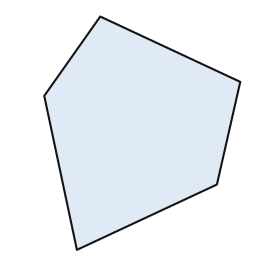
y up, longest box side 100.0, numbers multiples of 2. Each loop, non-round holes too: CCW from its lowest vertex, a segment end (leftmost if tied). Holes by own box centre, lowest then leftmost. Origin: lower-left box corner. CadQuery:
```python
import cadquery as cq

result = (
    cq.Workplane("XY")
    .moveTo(14.0, 0.0)
    .lineTo(74.0, 28.0)
    .lineTo(84.0, 72.0)
    .lineTo(24.0, 100.0)
    .lineTo(0.0, 66.0)
    .close()
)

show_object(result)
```